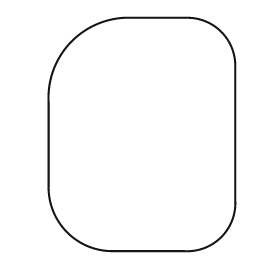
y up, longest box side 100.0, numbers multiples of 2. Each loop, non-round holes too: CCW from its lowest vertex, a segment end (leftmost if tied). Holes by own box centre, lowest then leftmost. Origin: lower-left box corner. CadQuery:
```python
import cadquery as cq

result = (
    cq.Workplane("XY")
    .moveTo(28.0, 0.0)
    .lineTo(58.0, 0.0)
    .threePointArc((74.0, 6.0), (80.0, 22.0))
    .lineTo(80.0, 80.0)
    .threePointArc((74.0, 94.0), (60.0, 100.0))
    .lineTo(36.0, 100.0)
    .threePointArc((10.0, 90.0), (0.0, 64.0))
    .lineTo(0.0, 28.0)
    .threePointArc((8.0, 8.0), (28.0, 0.0))
    .close()
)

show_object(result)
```